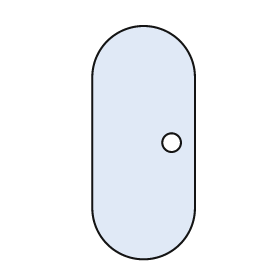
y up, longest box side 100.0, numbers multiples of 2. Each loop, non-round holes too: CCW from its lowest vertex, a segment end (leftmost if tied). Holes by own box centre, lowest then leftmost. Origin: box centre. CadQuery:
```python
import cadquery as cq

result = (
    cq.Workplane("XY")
    .moveTo(-22.0, -28.0)
    .threePointArc((0.0, -50.0), (22.0, -28.0))
    .lineTo(22.0, 28.0)
    .threePointArc((0.0, 50.0), (-22.0, 28.0))
    .close()
    .moveTo(12.0, 0.0)
    .circle(4.0)
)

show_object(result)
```